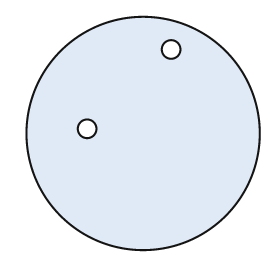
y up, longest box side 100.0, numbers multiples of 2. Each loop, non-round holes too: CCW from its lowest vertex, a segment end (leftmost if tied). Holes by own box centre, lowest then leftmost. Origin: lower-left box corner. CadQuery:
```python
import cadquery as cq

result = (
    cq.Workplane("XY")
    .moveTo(50.0, 50.0)
    .circle(50.0)
    .moveTo(26.0, 52.0)
    .circle(4.0)
    .moveTo(62.0, 86.0)
    .circle(4.0)
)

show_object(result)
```